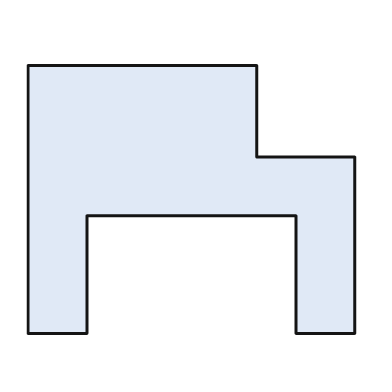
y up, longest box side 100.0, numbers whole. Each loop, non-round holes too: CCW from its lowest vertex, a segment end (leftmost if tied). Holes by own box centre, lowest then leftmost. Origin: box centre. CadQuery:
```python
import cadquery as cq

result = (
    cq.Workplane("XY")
    .moveTo(-50.0, -41.0)
    .lineTo(-32.0, -41.0)
    .lineTo(-32.0, -5.0)
    .lineTo(32.0, -5.0)
    .lineTo(32.0, -41.0)
    .lineTo(50.0, -41.0)
    .lineTo(50.0, 13.0)
    .lineTo(20.0, 13.0)
    .lineTo(20.0, 41.0)
    .lineTo(-50.0, 41.0)
    .close()
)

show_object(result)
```